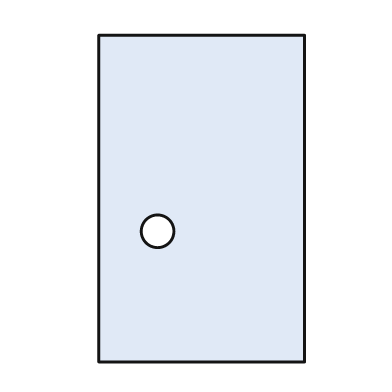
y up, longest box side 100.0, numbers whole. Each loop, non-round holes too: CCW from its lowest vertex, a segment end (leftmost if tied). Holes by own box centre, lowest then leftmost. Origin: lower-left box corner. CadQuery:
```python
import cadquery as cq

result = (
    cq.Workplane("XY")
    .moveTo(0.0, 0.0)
    .lineTo(63.0, 0.0)
    .lineTo(63.0, 100.0)
    .lineTo(0.0, 100.0)
    .close()
    .moveTo(18.0, 40.0)
    .circle(5.0)
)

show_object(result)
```